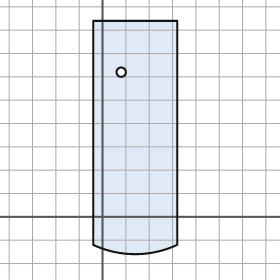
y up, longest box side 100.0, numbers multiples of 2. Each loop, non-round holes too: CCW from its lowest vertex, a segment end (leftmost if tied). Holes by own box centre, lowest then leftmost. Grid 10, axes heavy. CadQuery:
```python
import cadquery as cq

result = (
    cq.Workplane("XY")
    .moveTo(-4.0, -12.0)
    .threePointArc((14.0, -16.0), (32.0, -12.0))
    .lineTo(32.0, 84.0)
    .lineTo(-4.0, 84.0)
    .close()
    .moveTo(8.0, 62.0)
    .circle(2.0)
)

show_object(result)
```